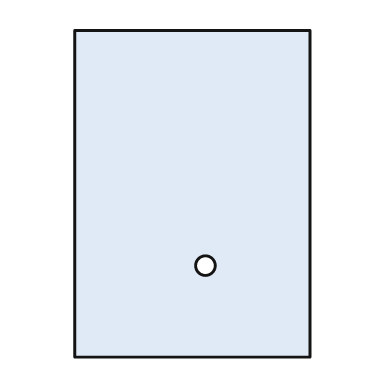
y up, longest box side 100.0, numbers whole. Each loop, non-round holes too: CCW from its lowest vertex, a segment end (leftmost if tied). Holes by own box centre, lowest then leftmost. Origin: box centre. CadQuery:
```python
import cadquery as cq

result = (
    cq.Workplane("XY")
    .moveTo(-36.0, -50.0)
    .lineTo(36.0, -50.0)
    .lineTo(36.0, 50.0)
    .lineTo(-36.0, 50.0)
    .close()
    .moveTo(4.0, -22.0)
    .circle(3.0)
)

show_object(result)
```